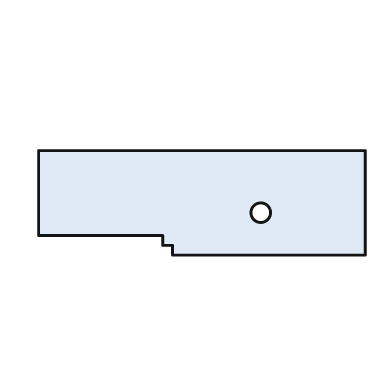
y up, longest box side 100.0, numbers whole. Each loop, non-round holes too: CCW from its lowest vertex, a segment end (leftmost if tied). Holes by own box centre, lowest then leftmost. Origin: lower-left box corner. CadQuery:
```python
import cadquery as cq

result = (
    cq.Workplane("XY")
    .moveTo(41.0, 0.0)
    .lineTo(100.0, 0.0)
    .lineTo(100.0, 32.0)
    .lineTo(0.0, 32.0)
    .lineTo(0.0, 6.0)
    .lineTo(38.0, 6.0)
    .lineTo(38.0, 3.0)
    .lineTo(41.0, 3.0)
    .close()
    .moveTo(68.0, 13.0)
    .circle(3.0)
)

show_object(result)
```